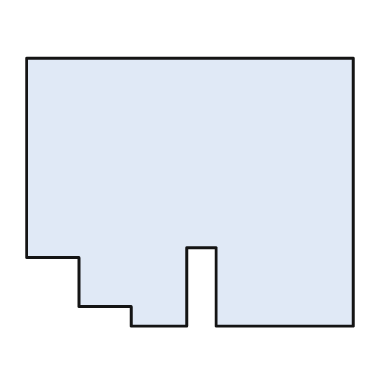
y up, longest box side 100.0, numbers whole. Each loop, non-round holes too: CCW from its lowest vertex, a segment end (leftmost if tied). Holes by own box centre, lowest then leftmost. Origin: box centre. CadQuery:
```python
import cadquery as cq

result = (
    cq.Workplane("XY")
    .moveTo(-18.0, -41.0)
    .lineTo(-1.0, -41.0)
    .lineTo(-1.0, -17.0)
    .lineTo(8.0, -17.0)
    .lineTo(8.0, -41.0)
    .lineTo(50.0, -41.0)
    .lineTo(50.0, 41.0)
    .lineTo(-50.0, 41.0)
    .lineTo(-50.0, -20.0)
    .lineTo(-34.0, -20.0)
    .lineTo(-34.0, -35.0)
    .lineTo(-18.0, -35.0)
    .close()
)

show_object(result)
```